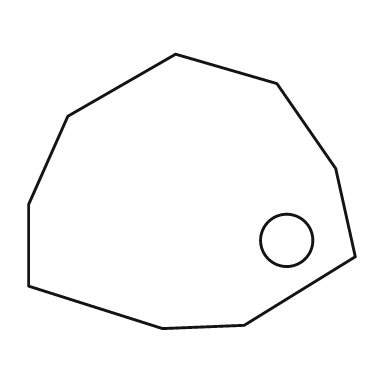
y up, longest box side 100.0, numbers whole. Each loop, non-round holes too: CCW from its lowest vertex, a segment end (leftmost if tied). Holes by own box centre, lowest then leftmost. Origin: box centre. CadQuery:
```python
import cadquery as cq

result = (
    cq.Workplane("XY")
    .moveTo(-9.0, -42.0)
    .lineTo(16.0, -41.0)
    .lineTo(50.0, -20.0)
    .lineTo(44.0, 7.0)
    .lineTo(26.0, 33.0)
    .lineTo(-5.0, 42.0)
    .lineTo(-38.0, 23.0)
    .lineTo(-50.0, -4.0)
    .lineTo(-50.0, -29.0)
    .close()
    .moveTo(29.0, -15.0)
    .circle(8.0)
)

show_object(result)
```